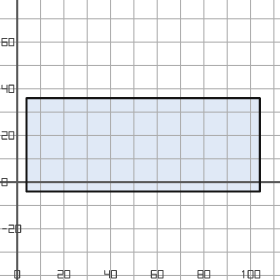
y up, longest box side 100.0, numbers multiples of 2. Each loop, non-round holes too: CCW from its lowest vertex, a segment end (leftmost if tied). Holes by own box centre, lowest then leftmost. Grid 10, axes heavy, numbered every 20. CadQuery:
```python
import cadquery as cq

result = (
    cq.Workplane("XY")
    .moveTo(4.0, -4.0)
    .lineTo(104.0, -4.0)
    .lineTo(104.0, 36.0)
    .lineTo(4.0, 36.0)
    .close()
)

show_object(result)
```